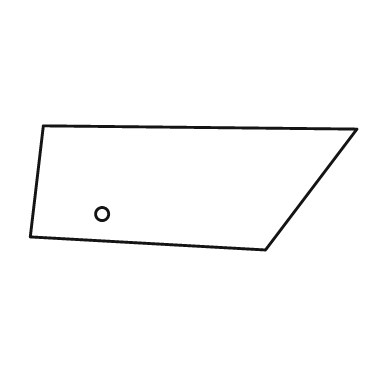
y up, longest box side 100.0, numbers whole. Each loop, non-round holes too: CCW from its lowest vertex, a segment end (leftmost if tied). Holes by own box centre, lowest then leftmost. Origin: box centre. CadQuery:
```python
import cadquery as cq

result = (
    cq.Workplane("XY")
    .moveTo(22.0, -19.0)
    .lineTo(50.0, 18.0)
    .lineTo(-46.0, 19.0)
    .lineTo(-50.0, -15.0)
    .close()
    .moveTo(-28.0, -8.0)
    .circle(2.0)
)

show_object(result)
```